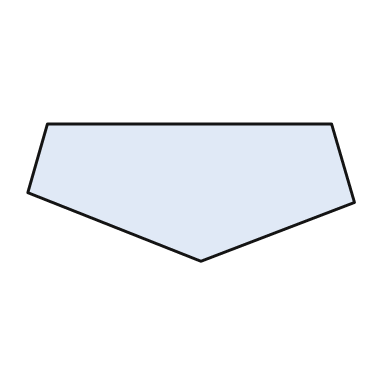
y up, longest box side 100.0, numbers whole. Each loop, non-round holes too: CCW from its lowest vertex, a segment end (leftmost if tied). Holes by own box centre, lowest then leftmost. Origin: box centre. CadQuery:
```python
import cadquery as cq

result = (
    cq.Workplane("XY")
    .moveTo(3.0, -21.0)
    .lineTo(50.0, -3.0)
    .lineTo(43.0, 21.0)
    .lineTo(-44.0, 21.0)
    .lineTo(-50.0, 0.0)
    .close()
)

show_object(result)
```